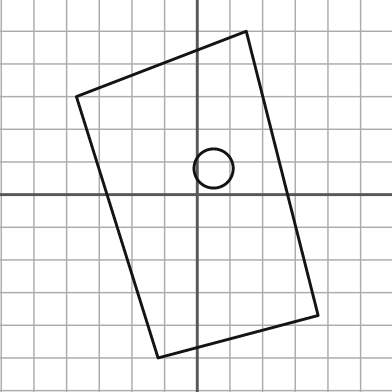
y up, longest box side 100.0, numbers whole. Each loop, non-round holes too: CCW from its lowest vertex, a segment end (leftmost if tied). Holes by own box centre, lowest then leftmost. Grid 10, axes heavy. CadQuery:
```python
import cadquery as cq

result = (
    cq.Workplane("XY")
    .moveTo(-12.0, -50.0)
    .lineTo(37.0, -37.0)
    .lineTo(15.0, 50.0)
    .lineTo(-37.0, 30.0)
    .close()
    .moveTo(5.0, 8.0)
    .circle(6.0)
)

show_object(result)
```